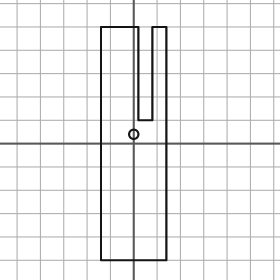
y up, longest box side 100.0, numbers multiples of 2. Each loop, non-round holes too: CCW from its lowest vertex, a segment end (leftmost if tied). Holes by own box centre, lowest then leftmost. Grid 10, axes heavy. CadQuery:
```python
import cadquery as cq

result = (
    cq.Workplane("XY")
    .moveTo(-14.0, -50.0)
    .lineTo(14.0, -50.0)
    .lineTo(14.0, 50.0)
    .lineTo(8.0, 50.0)
    .lineTo(8.0, 10.0)
    .lineTo(2.0, 10.0)
    .lineTo(2.0, 50.0)
    .lineTo(-14.0, 50.0)
    .close()
    .moveTo(0.0, 4.0)
    .circle(2.0)
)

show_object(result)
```